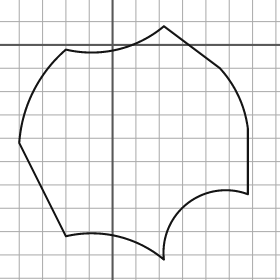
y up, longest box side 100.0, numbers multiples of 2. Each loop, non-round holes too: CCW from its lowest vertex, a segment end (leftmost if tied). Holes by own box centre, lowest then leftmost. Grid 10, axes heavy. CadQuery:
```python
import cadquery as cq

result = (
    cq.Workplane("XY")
    .moveTo(22.0, -92.0)
    .threePointArc((32.0, -68.0), (58.0, -64.0))
    .lineTo(58.0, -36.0)
    .threePointArc((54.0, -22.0), (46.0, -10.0))
    .lineTo(22.0, 8.0)
    .threePointArc((2.0, -2.0), (-20.0, -2.0))
    .threePointArc((-34.0, -20.0), (-40.0, -42.0))
    .lineTo(-20.0, -82.0)
    .threePointArc((2.0, -82.0), (22.0, -92.0))
    .close()
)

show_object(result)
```